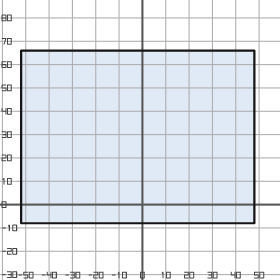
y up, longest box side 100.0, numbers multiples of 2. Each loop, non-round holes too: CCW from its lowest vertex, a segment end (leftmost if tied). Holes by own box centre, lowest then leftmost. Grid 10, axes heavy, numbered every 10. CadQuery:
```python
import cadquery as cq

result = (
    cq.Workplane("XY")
    .moveTo(-52.0, -8.0)
    .lineTo(48.0, -8.0)
    .lineTo(48.0, 66.0)
    .lineTo(-52.0, 66.0)
    .close()
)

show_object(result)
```